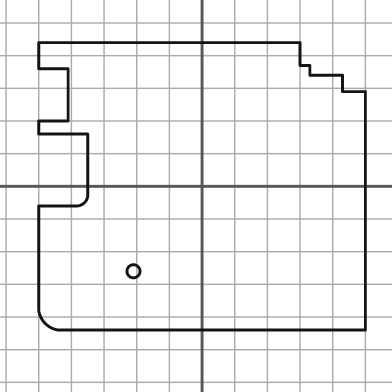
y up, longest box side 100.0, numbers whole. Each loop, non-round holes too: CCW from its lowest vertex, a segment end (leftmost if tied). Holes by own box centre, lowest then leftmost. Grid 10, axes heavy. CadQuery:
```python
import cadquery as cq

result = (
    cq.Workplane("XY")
    .moveTo(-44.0, -44.0)
    .lineTo(50.0, -44.0)
    .lineTo(50.0, 29.0)
    .lineTo(43.0, 29.0)
    .lineTo(43.0, 34.0)
    .lineTo(33.0, 34.0)
    .lineTo(33.0, 37.0)
    .lineTo(30.0, 37.0)
    .lineTo(30.0, 44.0)
    .lineTo(-50.0, 44.0)
    .lineTo(-50.0, 36.0)
    .lineTo(-41.0, 36.0)
    .lineTo(-41.0, 20.0)
    .lineTo(-50.0, 20.0)
    .lineTo(-50.0, 16.0)
    .lineTo(-35.0, 16.0)
    .lineTo(-35.0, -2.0)
    .threePointArc((-36.0, -5.0), (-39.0, -6.0))
    .lineTo(-50.0, -6.0)
    .lineTo(-50.0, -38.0)
    .threePointArc((-48.0, -42.0), (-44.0, -44.0))
    .close()
    .moveTo(-21.0, -26.0)
    .circle(2.0)
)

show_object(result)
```